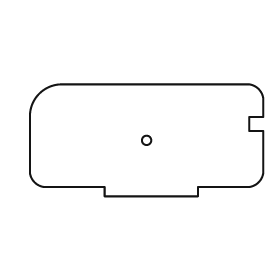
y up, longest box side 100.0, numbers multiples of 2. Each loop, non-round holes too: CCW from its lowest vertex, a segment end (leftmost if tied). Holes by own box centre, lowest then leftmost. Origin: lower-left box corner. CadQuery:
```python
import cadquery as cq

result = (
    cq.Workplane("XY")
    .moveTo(32.0, 0.0)
    .lineTo(72.0, 0.0)
    .lineTo(72.0, 4.0)
    .lineTo(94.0, 4.0)
    .threePointArc((98.0, 6.0), (100.0, 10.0))
    .lineTo(100.0, 28.0)
    .lineTo(94.0, 28.0)
    .lineTo(94.0, 34.0)
    .lineTo(100.0, 34.0)
    .lineTo(100.0, 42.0)
    .threePointArc((98.0, 46.0), (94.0, 48.0))
    .lineTo(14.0, 48.0)
    .threePointArc((4.0, 44.0), (0.0, 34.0))
    .lineTo(0.0, 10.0)
    .threePointArc((2.0, 6.0), (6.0, 4.0))
    .lineTo(32.0, 4.0)
    .close()
    .moveTo(50.0, 24.0)
    .circle(2.0)
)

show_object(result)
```